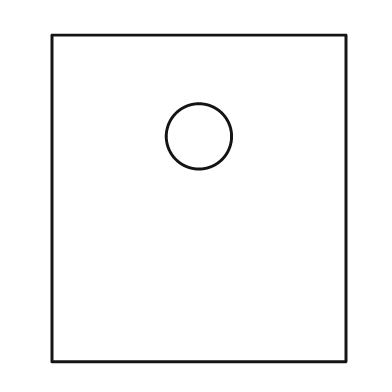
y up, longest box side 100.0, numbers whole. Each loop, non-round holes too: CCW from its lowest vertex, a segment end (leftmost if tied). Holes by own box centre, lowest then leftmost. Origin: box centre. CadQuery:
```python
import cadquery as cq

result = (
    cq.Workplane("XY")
    .moveTo(-45.0, -50.0)
    .lineTo(45.0, -50.0)
    .lineTo(45.0, 50.0)
    .lineTo(-45.0, 50.0)
    .close()
    .moveTo(0.0, 19.0)
    .circle(10.0)
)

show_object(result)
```